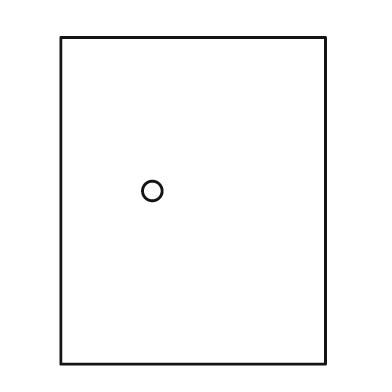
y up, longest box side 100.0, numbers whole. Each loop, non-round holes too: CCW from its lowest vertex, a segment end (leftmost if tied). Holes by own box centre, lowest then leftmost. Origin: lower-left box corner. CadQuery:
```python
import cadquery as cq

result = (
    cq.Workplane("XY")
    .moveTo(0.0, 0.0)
    .lineTo(81.0, 0.0)
    .lineTo(81.0, 100.0)
    .lineTo(0.0, 100.0)
    .close()
    .moveTo(28.0, 53.0)
    .circle(3.0)
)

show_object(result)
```